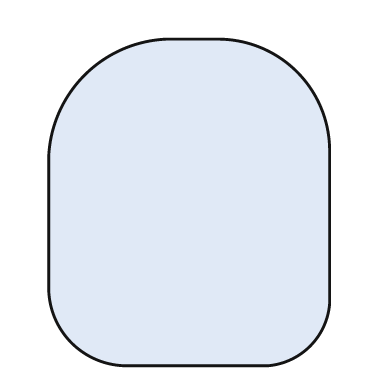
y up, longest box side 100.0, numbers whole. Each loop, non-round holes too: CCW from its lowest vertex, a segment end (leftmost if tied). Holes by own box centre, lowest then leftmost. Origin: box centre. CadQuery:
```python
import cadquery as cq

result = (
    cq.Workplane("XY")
    .moveTo(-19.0, -50.0)
    .lineTo(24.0, -50.0)
    .threePointArc((37.0, -44.0), (43.0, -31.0))
    .lineTo(43.0, 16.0)
    .threePointArc((33.0, 40.0), (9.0, 50.0))
    .lineTo(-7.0, 50.0)
    .threePointArc((-32.0, 39.0), (-43.0, 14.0))
    .lineTo(-43.0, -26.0)
    .threePointArc((-36.0, -43.0), (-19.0, -50.0))
    .close()
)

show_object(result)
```